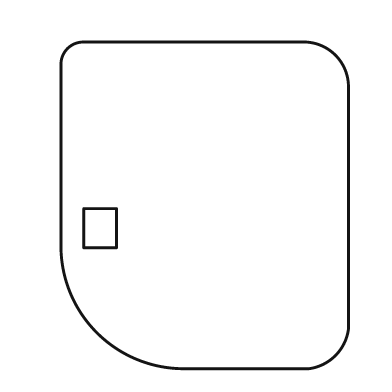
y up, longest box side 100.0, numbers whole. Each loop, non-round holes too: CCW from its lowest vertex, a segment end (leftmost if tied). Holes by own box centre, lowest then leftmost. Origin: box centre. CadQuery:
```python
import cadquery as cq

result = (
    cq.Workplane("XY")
    .moveTo(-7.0, -50.0)
    .lineTo(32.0, -50.0)
    .threePointArc((40.0, -46.0), (44.0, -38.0))
    .lineTo(44.0, 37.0)
    .threePointArc((40.0, 46.0), (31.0, 50.0))
    .lineTo(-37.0, 50.0)
    .threePointArc((-42.0, 48.0), (-44.0, 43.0))
    .lineTo(-44.0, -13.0)
    .threePointArc((-33.0, -39.0), (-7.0, -50.0))
    .close()
    .moveTo(-37.0, -13.0)
    .lineTo(-27.0, -13.0)
    .lineTo(-27.0, -1.0)
    .lineTo(-37.0, -1.0)
    .close()
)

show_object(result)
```